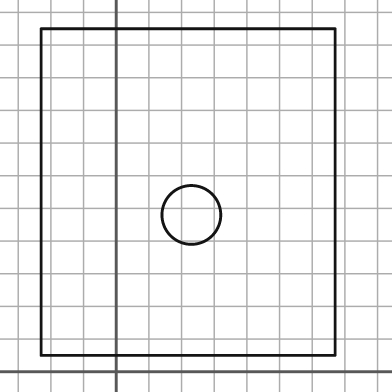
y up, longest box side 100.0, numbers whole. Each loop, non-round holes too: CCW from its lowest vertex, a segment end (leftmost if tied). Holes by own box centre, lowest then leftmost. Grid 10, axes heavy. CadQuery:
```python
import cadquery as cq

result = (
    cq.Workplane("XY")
    .moveTo(-23.0, 5.0)
    .lineTo(67.0, 5.0)
    .lineTo(67.0, 105.0)
    .lineTo(-23.0, 105.0)
    .close()
    .moveTo(23.0, 48.0)
    .circle(9.0)
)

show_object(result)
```